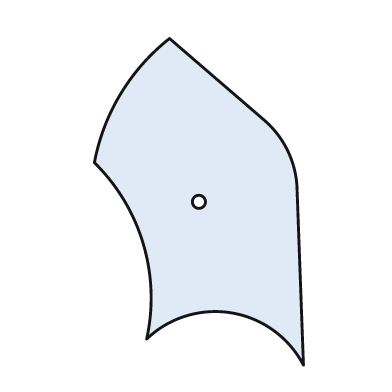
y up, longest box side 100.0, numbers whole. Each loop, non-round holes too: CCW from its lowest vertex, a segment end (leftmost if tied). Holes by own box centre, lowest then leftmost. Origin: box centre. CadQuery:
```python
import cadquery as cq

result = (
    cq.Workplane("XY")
    .moveTo(32.0, -50.0)
    .lineTo(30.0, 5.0)
    .threePointArc((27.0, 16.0), (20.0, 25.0))
    .lineTo(-9.0, 50.0)
    .threePointArc((-24.0, 33.0), (-32.0, 12.0))
    .threePointArc((-17.0, -13.0), (-16.0, -42.0))
    .threePointArc((10.0, -34.0), (32.0, -50.0))
    .close()
    .moveTo(0.0, 0.0)
    .circle(2.0)
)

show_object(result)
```